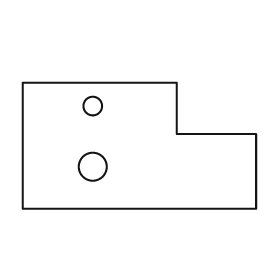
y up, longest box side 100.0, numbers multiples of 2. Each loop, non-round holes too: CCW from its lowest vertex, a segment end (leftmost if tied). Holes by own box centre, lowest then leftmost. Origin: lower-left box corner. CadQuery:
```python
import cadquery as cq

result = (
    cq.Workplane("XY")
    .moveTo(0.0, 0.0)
    .lineTo(100.0, 0.0)
    .lineTo(100.0, 32.0)
    .lineTo(66.0, 32.0)
    .lineTo(66.0, 54.0)
    .lineTo(0.0, 54.0)
    .close()
    .moveTo(30.0, 18.0)
    .circle(6.0)
    .moveTo(30.0, 44.0)
    .circle(4.0)
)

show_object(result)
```